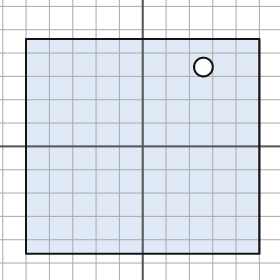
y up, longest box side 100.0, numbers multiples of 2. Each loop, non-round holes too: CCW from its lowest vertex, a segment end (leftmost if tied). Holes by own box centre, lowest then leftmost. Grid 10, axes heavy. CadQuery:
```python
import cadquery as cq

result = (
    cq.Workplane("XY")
    .moveTo(-50.0, -46.0)
    .lineTo(50.0, -46.0)
    .lineTo(50.0, 46.0)
    .lineTo(-50.0, 46.0)
    .close()
    .moveTo(26.0, 34.0)
    .circle(4.0)
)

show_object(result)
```